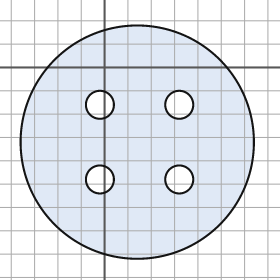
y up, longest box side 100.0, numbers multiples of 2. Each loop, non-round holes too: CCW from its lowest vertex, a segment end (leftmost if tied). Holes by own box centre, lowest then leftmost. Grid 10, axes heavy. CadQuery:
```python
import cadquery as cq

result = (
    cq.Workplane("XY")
    .moveTo(14.0, -32.0)
    .circle(50.0)
    .moveTo(-2.0, -48.0)
    .circle(6.0)
    .moveTo(32.0, -48.0)
    .circle(6.0)
    .moveTo(-2.0, -16.0)
    .circle(6.0)
    .moveTo(32.0, -16.0)
    .circle(6.0)
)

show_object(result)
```